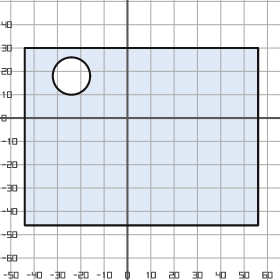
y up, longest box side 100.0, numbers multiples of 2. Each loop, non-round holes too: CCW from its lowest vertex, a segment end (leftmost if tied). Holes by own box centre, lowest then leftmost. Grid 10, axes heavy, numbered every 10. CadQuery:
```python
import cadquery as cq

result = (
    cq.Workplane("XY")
    .moveTo(-44.0, -46.0)
    .lineTo(56.0, -46.0)
    .lineTo(56.0, 30.0)
    .lineTo(-44.0, 30.0)
    .close()
    .moveTo(-24.0, 18.0)
    .circle(8.0)
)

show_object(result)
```